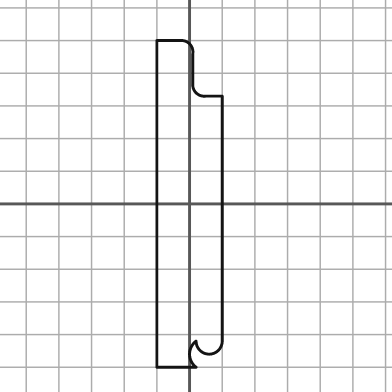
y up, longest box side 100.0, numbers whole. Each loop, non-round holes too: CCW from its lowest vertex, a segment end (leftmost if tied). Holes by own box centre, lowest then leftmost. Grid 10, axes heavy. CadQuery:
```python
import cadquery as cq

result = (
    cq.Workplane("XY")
    .moveTo(-10.0, -50.0)
    .lineTo(2.0, -50.0)
    .threePointArc((0.0, -46.0), (2.0, -42.0))
    .threePointArc((6.0, -46.0), (10.0, -42.0))
    .lineTo(10.0, 33.0)
    .lineTo(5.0, 33.0)
    .threePointArc((2.0, 34.0), (1.0, 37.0))
    .lineTo(1.0, 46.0)
    .threePointArc((0.0, 49.0), (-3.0, 50.0))
    .lineTo(-10.0, 50.0)
    .close()
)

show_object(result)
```